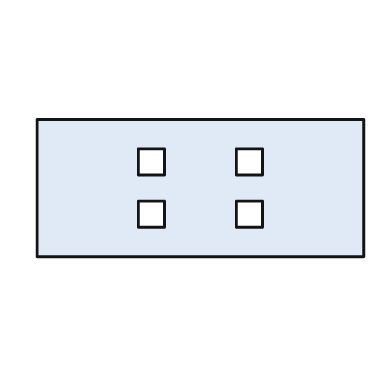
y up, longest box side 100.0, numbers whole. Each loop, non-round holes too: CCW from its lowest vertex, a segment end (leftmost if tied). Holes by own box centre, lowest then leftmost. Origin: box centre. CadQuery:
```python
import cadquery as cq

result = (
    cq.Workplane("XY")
    .moveTo(-50.0, -21.0)
    .lineTo(50.0, -21.0)
    .lineTo(50.0, 21.0)
    .lineTo(-50.0, 21.0)
    .close()
    .moveTo(-19.0, -12.0)
    .lineTo(-11.0, -12.0)
    .lineTo(-11.0, -4.0)
    .lineTo(-19.0, -4.0)
    .close()
    .moveTo(11.0, -12.0)
    .lineTo(19.0, -12.0)
    .lineTo(19.0, -4.0)
    .lineTo(11.0, -4.0)
    .close()
    .moveTo(-19.0, 4.0)
    .lineTo(-11.0, 4.0)
    .lineTo(-11.0, 12.0)
    .lineTo(-19.0, 12.0)
    .close()
    .moveTo(11.0, 4.0)
    .lineTo(19.0, 4.0)
    .lineTo(19.0, 12.0)
    .lineTo(11.0, 12.0)
    .close()
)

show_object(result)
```